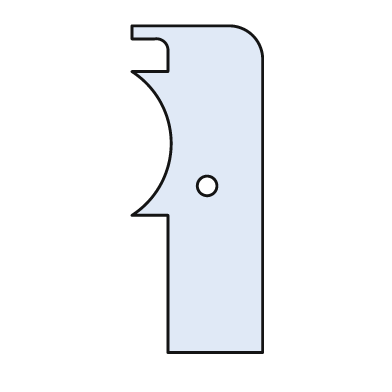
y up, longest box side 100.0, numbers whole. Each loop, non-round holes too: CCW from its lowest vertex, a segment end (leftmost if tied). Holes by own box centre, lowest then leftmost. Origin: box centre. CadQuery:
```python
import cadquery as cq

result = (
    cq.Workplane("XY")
    .moveTo(-9.0, -50.0)
    .lineTo(20.0, -50.0)
    .lineTo(20.0, 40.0)
    .threePointArc((17.0, 47.0), (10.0, 50.0))
    .lineTo(-20.0, 50.0)
    .lineTo(-20.0, 46.0)
    .lineTo(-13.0, 46.0)
    .threePointArc((-10.0, 45.0), (-9.0, 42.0))
    .lineTo(-9.0, 36.0)
    .lineTo(-20.0, 36.0)
    .threePointArc((-8.0, 14.0), (-20.0, -8.0))
    .lineTo(-9.0, -8.0)
    .close()
    .moveTo(3.0, 1.0)
    .circle(3.0)
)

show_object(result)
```